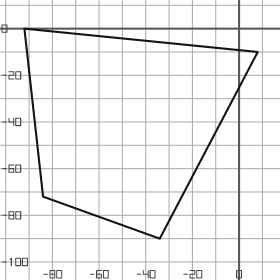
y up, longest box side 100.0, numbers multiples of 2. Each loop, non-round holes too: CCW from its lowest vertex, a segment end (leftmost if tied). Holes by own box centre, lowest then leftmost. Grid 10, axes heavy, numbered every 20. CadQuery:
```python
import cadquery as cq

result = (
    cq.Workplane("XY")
    .moveTo(-34.0, -90.0)
    .lineTo(8.0, -10.0)
    .lineTo(-92.0, 0.0)
    .lineTo(-84.0, -72.0)
    .close()
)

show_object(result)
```